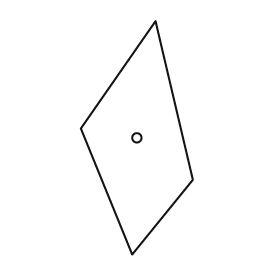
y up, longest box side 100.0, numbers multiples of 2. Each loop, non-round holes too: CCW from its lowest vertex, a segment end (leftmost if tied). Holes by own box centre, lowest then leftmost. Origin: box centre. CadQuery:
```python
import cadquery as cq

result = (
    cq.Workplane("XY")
    .moveTo(-2.0, -50.0)
    .lineTo(24.0, -18.0)
    .lineTo(8.0, 50.0)
    .lineTo(-24.0, 4.0)
    .close()
    .moveTo(0.0, 0.0)
    .circle(2.0)
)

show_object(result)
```